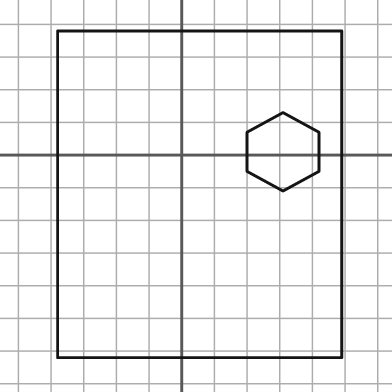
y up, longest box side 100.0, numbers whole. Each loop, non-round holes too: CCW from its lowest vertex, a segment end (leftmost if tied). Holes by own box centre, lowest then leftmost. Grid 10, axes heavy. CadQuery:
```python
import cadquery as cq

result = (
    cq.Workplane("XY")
    .moveTo(-38.0, -62.0)
    .lineTo(49.0, -62.0)
    .lineTo(49.0, 38.0)
    .lineTo(-38.0, 38.0)
    .close()
    .moveTo(31.0, -11.0)
    .lineTo(42.0, -5.0)
    .lineTo(42.0, 7.0)
    .lineTo(31.0, 13.0)
    .lineTo(20.0, 7.0)
    .lineTo(20.0, -5.0)
    .close()
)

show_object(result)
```